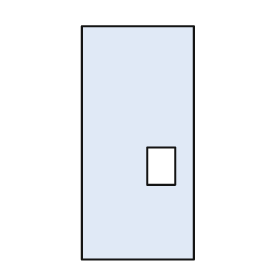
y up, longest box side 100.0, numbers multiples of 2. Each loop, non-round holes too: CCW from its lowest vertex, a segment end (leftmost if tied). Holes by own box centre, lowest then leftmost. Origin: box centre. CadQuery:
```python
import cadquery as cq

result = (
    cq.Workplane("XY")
    .moveTo(-24.0, -50.0)
    .lineTo(24.0, -50.0)
    .lineTo(24.0, 50.0)
    .lineTo(-24.0, 50.0)
    .close()
    .moveTo(4.0, -18.0)
    .lineTo(16.0, -18.0)
    .lineTo(16.0, -2.0)
    .lineTo(4.0, -2.0)
    .close()
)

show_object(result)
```